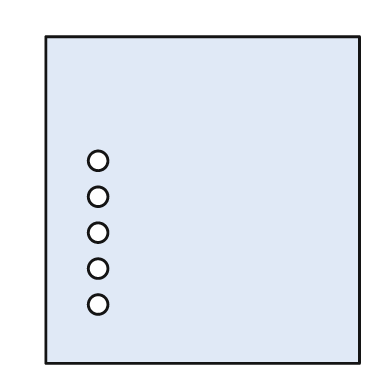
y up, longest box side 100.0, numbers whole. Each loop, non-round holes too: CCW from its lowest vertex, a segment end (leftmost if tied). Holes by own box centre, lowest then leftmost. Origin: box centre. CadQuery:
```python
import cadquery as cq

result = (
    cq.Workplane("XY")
    .moveTo(-48.0, -50.0)
    .lineTo(48.0, -50.0)
    .lineTo(48.0, 50.0)
    .lineTo(-48.0, 50.0)
    .close()
    .moveTo(-32.0, -32.0)
    .circle(3.0)
    .moveTo(-32.0, -21.0)
    .circle(3.0)
    .moveTo(-32.0, -10.0)
    .circle(3.0)
    .moveTo(-32.0, 1.0)
    .circle(3.0)
    .moveTo(-32.0, 12.0)
    .circle(3.0)
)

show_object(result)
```